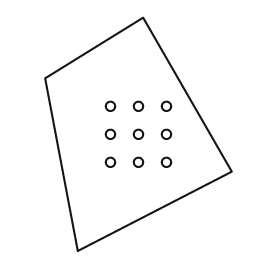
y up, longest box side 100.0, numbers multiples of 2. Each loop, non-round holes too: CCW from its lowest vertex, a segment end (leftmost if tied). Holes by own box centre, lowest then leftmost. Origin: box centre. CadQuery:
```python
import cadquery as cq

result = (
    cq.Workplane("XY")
    .moveTo(-26.0, -50.0)
    .lineTo(40.0, -16.0)
    .lineTo(2.0, 50.0)
    .lineTo(-40.0, 24.0)
    .close()
    .moveTo(-12.0, -12.0)
    .circle(2.0)
    .moveTo(0.0, -12.0)
    .circle(2.0)
    .moveTo(12.0, -12.0)
    .circle(2.0)
    .moveTo(-12.0, 0.0)
    .circle(2.0)
    .moveTo(0.0, 0.0)
    .circle(2.0)
    .moveTo(12.0, 0.0)
    .circle(2.0)
    .moveTo(-12.0, 12.0)
    .circle(2.0)
    .moveTo(0.0, 12.0)
    .circle(2.0)
    .moveTo(12.0, 12.0)
    .circle(2.0)
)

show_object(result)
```